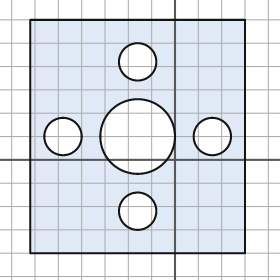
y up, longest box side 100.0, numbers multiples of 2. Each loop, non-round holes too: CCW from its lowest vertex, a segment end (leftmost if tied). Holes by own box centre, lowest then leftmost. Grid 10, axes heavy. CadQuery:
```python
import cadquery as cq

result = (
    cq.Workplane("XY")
    .moveTo(-62.0, -40.0)
    .lineTo(30.0, -40.0)
    .lineTo(30.0, 60.0)
    .lineTo(-62.0, 60.0)
    .close()
    .moveTo(-16.0, -22.0)
    .circle(8.0)
    .moveTo(-48.0, 10.0)
    .circle(8.0)
    .moveTo(-16.0, 10.0)
    .circle(16.0)
    .moveTo(16.0, 10.0)
    .circle(8.0)
    .moveTo(-16.0, 42.0)
    .circle(8.0)
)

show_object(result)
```